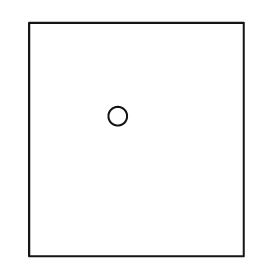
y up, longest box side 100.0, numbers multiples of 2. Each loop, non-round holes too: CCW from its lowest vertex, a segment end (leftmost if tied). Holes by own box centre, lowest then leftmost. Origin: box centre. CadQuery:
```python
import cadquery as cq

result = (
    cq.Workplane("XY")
    .moveTo(-46.0, -50.0)
    .lineTo(46.0, -50.0)
    .lineTo(46.0, 50.0)
    .lineTo(-46.0, 50.0)
    .close()
    .moveTo(-8.0, 10.0)
    .circle(4.0)
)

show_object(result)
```